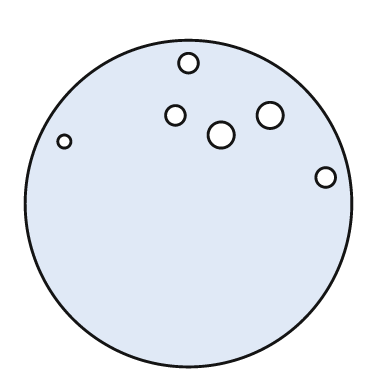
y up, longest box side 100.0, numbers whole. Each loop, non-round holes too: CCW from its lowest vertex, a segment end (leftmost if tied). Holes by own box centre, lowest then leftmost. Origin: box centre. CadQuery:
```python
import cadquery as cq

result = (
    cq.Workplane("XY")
    .moveTo(0.0, 0.0)
    .circle(50.0)
    .moveTo(42.0, 8.0)
    .circle(3.0)
    .moveTo(-38.0, 19.0)
    .circle(2.0)
    .moveTo(10.0, 21.0)
    .circle(4.0)
    .moveTo(-4.0, 27.0)
    .circle(3.0)
    .moveTo(25.0, 27.0)
    .circle(4.0)
    .moveTo(0.0, 43.0)
    .circle(3.0)
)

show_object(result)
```